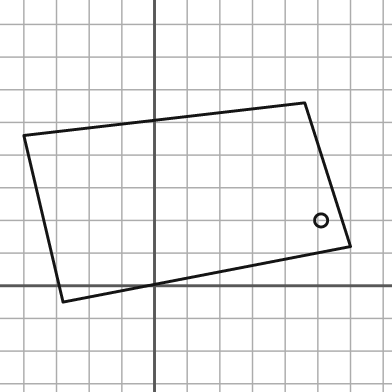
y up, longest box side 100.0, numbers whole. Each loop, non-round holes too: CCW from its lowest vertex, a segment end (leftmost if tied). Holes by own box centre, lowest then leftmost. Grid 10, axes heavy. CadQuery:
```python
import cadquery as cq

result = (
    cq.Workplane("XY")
    .moveTo(-28.0, -5.0)
    .lineTo(60.0, 12.0)
    .lineTo(46.0, 56.0)
    .lineTo(-40.0, 46.0)
    .close()
    .moveTo(51.0, 20.0)
    .circle(2.0)
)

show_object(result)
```